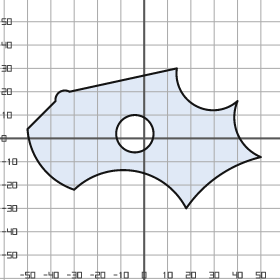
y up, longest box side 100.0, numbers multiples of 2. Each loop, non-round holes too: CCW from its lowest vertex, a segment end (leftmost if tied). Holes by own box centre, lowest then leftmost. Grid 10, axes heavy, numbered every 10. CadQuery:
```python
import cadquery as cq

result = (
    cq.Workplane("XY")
    .moveTo(18.0, -30.0)
    .threePointArc((32.0, -16.0), (50.0, -8.0))
    .threePointArc((40.0, 2.0), (40.0, 16.0))
    .threePointArc((22.0, 14.0), (14.0, 30.0))
    .lineTo(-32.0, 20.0)
    .threePointArc((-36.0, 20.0), (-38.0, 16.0))
    .lineTo(-50.0, 4.0)
    .threePointArc((-44.0, -12.0), (-30.0, -22.0))
    .threePointArc((-4.0, -14.0), (18.0, -30.0))
    .close()
    .moveTo(-4.0, 2.0)
    .circle(8.0)
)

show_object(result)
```